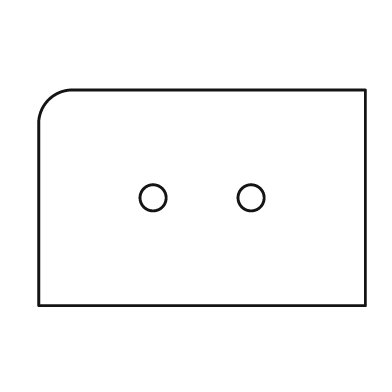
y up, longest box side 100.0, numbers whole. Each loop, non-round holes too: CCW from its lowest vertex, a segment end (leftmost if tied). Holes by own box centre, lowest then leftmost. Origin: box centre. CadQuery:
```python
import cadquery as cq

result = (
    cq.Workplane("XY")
    .moveTo(-50.0, -33.0)
    .lineTo(50.0, -33.0)
    .lineTo(50.0, 33.0)
    .lineTo(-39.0, 33.0)
    .threePointArc((-47.0, 30.0), (-50.0, 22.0))
    .close()
    .moveTo(-15.0, 0.0)
    .circle(4.0)
    .moveTo(15.0, 0.0)
    .circle(4.0)
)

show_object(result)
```